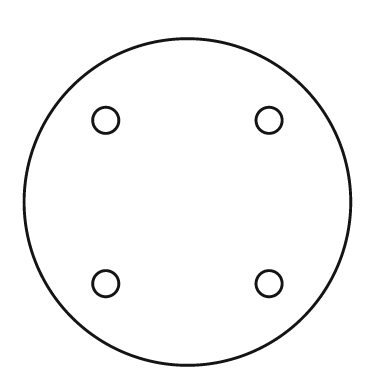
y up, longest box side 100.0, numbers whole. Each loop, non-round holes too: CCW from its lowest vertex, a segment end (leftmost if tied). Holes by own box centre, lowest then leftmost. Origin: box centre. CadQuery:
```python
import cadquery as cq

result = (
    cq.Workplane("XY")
    .moveTo(0.0, 0.0)
    .circle(50.0)
    .moveTo(-25.0, -25.0)
    .circle(4.0)
    .moveTo(25.0, -25.0)
    .circle(4.0)
    .moveTo(-25.0, 25.0)
    .circle(4.0)
    .moveTo(25.0, 25.0)
    .circle(4.0)
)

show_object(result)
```